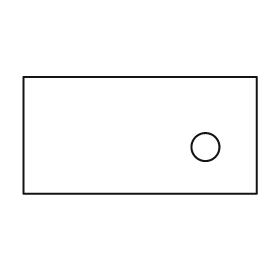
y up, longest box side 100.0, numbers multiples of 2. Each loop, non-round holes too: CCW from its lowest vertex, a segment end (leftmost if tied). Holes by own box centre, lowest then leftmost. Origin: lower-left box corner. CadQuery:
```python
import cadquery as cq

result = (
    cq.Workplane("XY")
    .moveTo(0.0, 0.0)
    .lineTo(100.0, 0.0)
    .lineTo(100.0, 50.0)
    .lineTo(0.0, 50.0)
    .close()
    .moveTo(78.0, 20.0)
    .circle(6.0)
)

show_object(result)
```